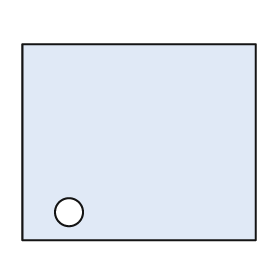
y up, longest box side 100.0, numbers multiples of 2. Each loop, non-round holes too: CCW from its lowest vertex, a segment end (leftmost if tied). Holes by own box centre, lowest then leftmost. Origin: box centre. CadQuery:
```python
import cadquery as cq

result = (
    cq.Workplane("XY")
    .moveTo(-50.0, -42.0)
    .lineTo(50.0, -42.0)
    .lineTo(50.0, 42.0)
    .lineTo(-50.0, 42.0)
    .close()
    .moveTo(-30.0, -30.0)
    .circle(6.0)
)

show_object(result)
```